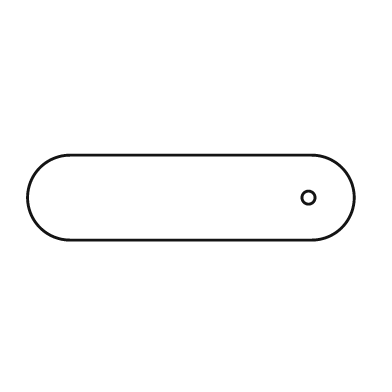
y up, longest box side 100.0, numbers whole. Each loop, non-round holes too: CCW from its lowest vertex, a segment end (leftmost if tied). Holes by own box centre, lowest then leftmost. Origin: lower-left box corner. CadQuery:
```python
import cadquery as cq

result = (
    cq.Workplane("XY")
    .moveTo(13.0, 0.0)
    .lineTo(87.0, 0.0)
    .threePointArc((100.0, 13.0), (87.0, 26.0))
    .lineTo(13.0, 26.0)
    .threePointArc((0.0, 13.0), (13.0, 0.0))
    .close()
    .moveTo(86.0, 13.0)
    .circle(2.0)
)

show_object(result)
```